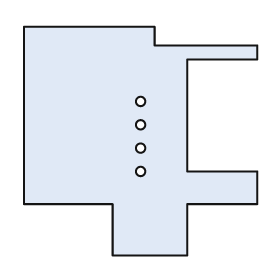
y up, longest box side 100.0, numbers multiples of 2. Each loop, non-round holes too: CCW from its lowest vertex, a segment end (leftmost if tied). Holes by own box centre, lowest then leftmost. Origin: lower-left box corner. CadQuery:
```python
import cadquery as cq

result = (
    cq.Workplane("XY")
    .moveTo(38.0, 0.0)
    .lineTo(70.0, 0.0)
    .lineTo(70.0, 22.0)
    .lineTo(100.0, 22.0)
    .lineTo(100.0, 36.0)
    .lineTo(70.0, 36.0)
    .lineTo(70.0, 84.0)
    .lineTo(100.0, 84.0)
    .lineTo(100.0, 90.0)
    .lineTo(56.0, 90.0)
    .lineTo(56.0, 98.0)
    .lineTo(0.0, 98.0)
    .lineTo(0.0, 22.0)
    .lineTo(38.0, 22.0)
    .close()
    .moveTo(50.0, 36.0)
    .circle(2.0)
    .moveTo(50.0, 46.0)
    .circle(2.0)
    .moveTo(50.0, 56.0)
    .circle(2.0)
    .moveTo(50.0, 66.0)
    .circle(2.0)
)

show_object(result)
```